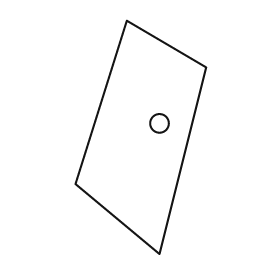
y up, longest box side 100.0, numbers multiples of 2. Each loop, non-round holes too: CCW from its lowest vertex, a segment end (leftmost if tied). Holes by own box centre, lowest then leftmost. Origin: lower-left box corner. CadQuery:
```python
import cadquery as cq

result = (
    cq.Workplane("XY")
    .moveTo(36.0, 0.0)
    .lineTo(56.0, 80.0)
    .lineTo(22.0, 100.0)
    .lineTo(0.0, 30.0)
    .close()
    .moveTo(36.0, 56.0)
    .circle(4.0)
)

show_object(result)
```